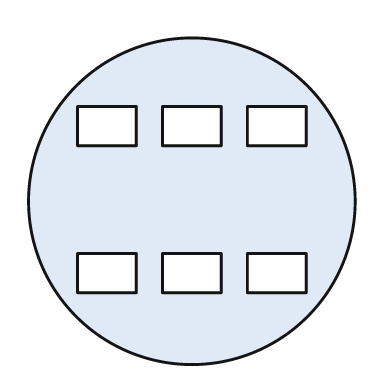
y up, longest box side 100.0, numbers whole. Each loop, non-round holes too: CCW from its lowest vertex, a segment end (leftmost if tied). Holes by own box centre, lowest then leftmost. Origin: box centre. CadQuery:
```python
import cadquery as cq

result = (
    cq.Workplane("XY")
    .moveTo(0.0, 0.0)
    .circle(50.0)
    .moveTo(-35.0, -28.0)
    .lineTo(-17.0, -28.0)
    .lineTo(-17.0, -16.0)
    .lineTo(-35.0, -16.0)
    .close()
    .moveTo(-9.0, -28.0)
    .lineTo(9.0, -28.0)
    .lineTo(9.0, -16.0)
    .lineTo(-9.0, -16.0)
    .close()
    .moveTo(17.0, -28.0)
    .lineTo(35.0, -28.0)
    .lineTo(35.0, -16.0)
    .lineTo(17.0, -16.0)
    .close()
    .moveTo(-35.0, 17.0)
    .lineTo(-17.0, 17.0)
    .lineTo(-17.0, 29.0)
    .lineTo(-35.0, 29.0)
    .close()
    .moveTo(-9.0, 17.0)
    .lineTo(9.0, 17.0)
    .lineTo(9.0, 29.0)
    .lineTo(-9.0, 29.0)
    .close()
    .moveTo(17.0, 17.0)
    .lineTo(35.0, 17.0)
    .lineTo(35.0, 29.0)
    .lineTo(17.0, 29.0)
    .close()
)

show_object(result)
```